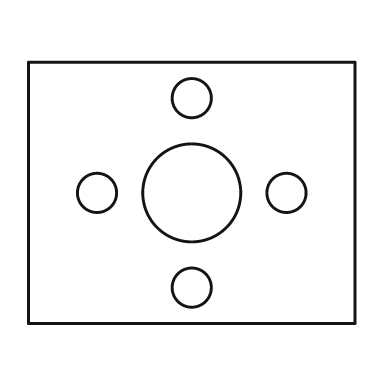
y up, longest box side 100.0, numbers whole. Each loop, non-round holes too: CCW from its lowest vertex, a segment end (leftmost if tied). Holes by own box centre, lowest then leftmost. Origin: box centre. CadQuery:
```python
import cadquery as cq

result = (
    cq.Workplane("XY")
    .moveTo(-50.0, -40.0)
    .lineTo(50.0, -40.0)
    .lineTo(50.0, 40.0)
    .lineTo(-50.0, 40.0)
    .close()
    .moveTo(0.0, -29.0)
    .circle(6.0)
    .moveTo(-29.0, 0.0)
    .circle(6.0)
    .moveTo(0.0, 0.0)
    .circle(15.0)
    .moveTo(29.0, 0.0)
    .circle(6.0)
    .moveTo(0.0, 29.0)
    .circle(6.0)
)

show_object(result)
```